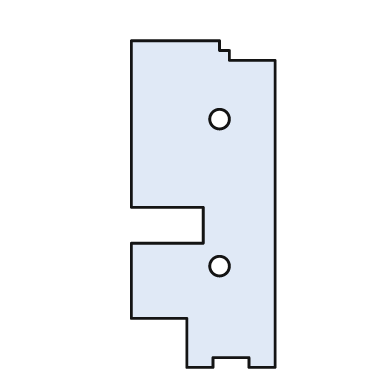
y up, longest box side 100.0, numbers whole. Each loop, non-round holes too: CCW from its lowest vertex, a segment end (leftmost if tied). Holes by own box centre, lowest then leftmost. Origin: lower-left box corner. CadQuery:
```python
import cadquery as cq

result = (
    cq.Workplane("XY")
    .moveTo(17.0, 0.0)
    .lineTo(25.0, 0.0)
    .lineTo(25.0, 3.0)
    .lineTo(36.0, 3.0)
    .lineTo(36.0, 0.0)
    .lineTo(44.0, 0.0)
    .lineTo(44.0, 94.0)
    .lineTo(30.0, 94.0)
    .lineTo(30.0, 97.0)
    .lineTo(27.0, 97.0)
    .lineTo(27.0, 100.0)
    .lineTo(0.0, 100.0)
    .lineTo(0.0, 49.0)
    .lineTo(22.0, 49.0)
    .lineTo(22.0, 38.0)
    .lineTo(0.0, 38.0)
    .lineTo(0.0, 15.0)
    .lineTo(17.0, 15.0)
    .close()
    .moveTo(27.0, 31.0)
    .circle(3.0)
    .moveTo(27.0, 76.0)
    .circle(3.0)
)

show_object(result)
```